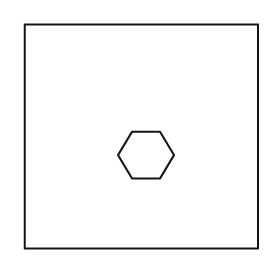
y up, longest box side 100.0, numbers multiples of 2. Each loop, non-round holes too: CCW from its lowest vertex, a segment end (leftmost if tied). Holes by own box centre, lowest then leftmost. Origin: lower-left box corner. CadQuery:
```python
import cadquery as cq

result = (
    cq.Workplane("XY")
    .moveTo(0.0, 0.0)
    .lineTo(100.0, 0.0)
    .lineTo(100.0, 96.0)
    .lineTo(0.0, 96.0)
    .close()
    .moveTo(46.0, 30.0)
    .lineTo(58.0, 30.0)
    .lineTo(64.0, 40.0)
    .lineTo(58.0, 50.0)
    .lineTo(46.0, 50.0)
    .lineTo(40.0, 40.0)
    .close()
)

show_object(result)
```